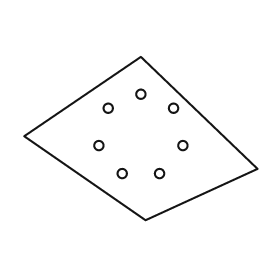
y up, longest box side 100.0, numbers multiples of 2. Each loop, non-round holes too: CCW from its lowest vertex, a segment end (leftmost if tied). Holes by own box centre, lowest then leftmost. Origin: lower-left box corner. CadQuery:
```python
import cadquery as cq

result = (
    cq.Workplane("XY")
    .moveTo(52.0, 0.0)
    .lineTo(100.0, 22.0)
    .lineTo(50.0, 70.0)
    .lineTo(0.0, 36.0)
    .close()
    .moveTo(42.0, 20.0)
    .circle(2.0)
    .moveTo(58.0, 20.0)
    .circle(2.0)
    .moveTo(32.0, 32.0)
    .circle(2.0)
    .moveTo(68.0, 32.0)
    .circle(2.0)
    .moveTo(36.0, 48.0)
    .circle(2.0)
    .moveTo(64.0, 48.0)
    .circle(2.0)
    .moveTo(50.0, 54.0)
    .circle(2.0)
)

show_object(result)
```